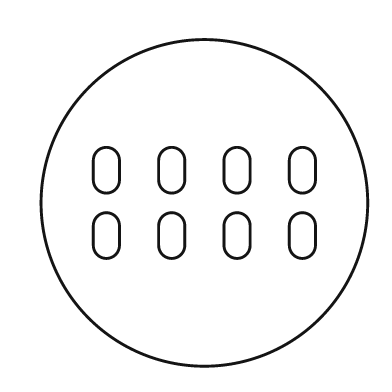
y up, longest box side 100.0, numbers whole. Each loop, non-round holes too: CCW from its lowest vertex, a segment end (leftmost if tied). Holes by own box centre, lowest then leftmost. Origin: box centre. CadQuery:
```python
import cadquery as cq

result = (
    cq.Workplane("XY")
    .moveTo(0.0, 0.0)
    .circle(50.0)
    .moveTo(-34.0, -13.0)
    .threePointArc((-30.0, -17.0), (-26.0, -13.0))
    .lineTo(-26.0, -7.0)
    .threePointArc((-30.0, -3.0), (-34.0, -7.0))
    .close()
    .moveTo(-14.0, -13.0)
    .threePointArc((-10.0, -17.0), (-6.0, -13.0))
    .lineTo(-6.0, -7.0)
    .threePointArc((-10.0, -3.0), (-14.0, -7.0))
    .close()
    .moveTo(6.0, -13.0)
    .threePointArc((10.0, -17.0), (14.0, -13.0))
    .lineTo(14.0, -7.0)
    .threePointArc((10.0, -3.0), (6.0, -7.0))
    .close()
    .moveTo(26.0, -13.0)
    .threePointArc((30.0, -17.0), (34.0, -13.0))
    .lineTo(34.0, -7.0)
    .threePointArc((30.0, -3.0), (26.0, -7.0))
    .close()
    .moveTo(-34.0, 7.0)
    .threePointArc((-30.0, 3.0), (-26.0, 7.0))
    .lineTo(-26.0, 13.0)
    .threePointArc((-30.0, 17.0), (-34.0, 13.0))
    .close()
    .moveTo(-14.0, 7.0)
    .threePointArc((-10.0, 3.0), (-6.0, 7.0))
    .lineTo(-6.0, 13.0)
    .threePointArc((-10.0, 17.0), (-14.0, 13.0))
    .close()
    .moveTo(6.0, 7.0)
    .threePointArc((10.0, 3.0), (14.0, 7.0))
    .lineTo(14.0, 13.0)
    .threePointArc((10.0, 17.0), (6.0, 13.0))
    .close()
    .moveTo(26.0, 7.0)
    .threePointArc((30.0, 3.0), (34.0, 7.0))
    .lineTo(34.0, 13.0)
    .threePointArc((30.0, 17.0), (26.0, 13.0))
    .close()
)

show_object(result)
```